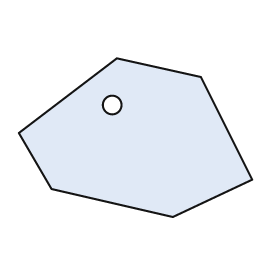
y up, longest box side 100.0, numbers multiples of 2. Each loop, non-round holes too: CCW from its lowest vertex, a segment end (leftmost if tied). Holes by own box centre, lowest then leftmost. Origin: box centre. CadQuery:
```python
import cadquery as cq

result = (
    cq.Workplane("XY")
    .moveTo(16.0, -34.0)
    .lineTo(50.0, -18.0)
    .lineTo(28.0, 26.0)
    .lineTo(-8.0, 34.0)
    .lineTo(-50.0, 2.0)
    .lineTo(-36.0, -22.0)
    .close()
    .moveTo(-10.0, 14.0)
    .circle(4.0)
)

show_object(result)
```